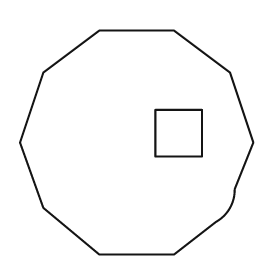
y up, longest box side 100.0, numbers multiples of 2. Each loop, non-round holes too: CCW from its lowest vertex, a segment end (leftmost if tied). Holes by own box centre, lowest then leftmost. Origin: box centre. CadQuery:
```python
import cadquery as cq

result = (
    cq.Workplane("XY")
    .moveTo(-16.0, -48.0)
    .lineTo(16.0, -48.0)
    .lineTo(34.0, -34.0)
    .threePointArc((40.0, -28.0), (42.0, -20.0))
    .lineTo(50.0, 0.0)
    .lineTo(40.0, 30.0)
    .lineTo(16.0, 48.0)
    .lineTo(-16.0, 48.0)
    .lineTo(-40.0, 30.0)
    .lineTo(-50.0, 0.0)
    .lineTo(-40.0, -28.0)
    .close()
    .moveTo(8.0, -6.0)
    .lineTo(28.0, -6.0)
    .lineTo(28.0, 14.0)
    .lineTo(8.0, 14.0)
    .close()
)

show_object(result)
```